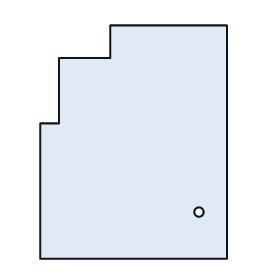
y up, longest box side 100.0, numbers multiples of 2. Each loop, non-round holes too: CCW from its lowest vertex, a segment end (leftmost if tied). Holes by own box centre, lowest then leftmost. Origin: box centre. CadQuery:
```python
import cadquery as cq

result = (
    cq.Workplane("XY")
    .moveTo(-40.0, -50.0)
    .lineTo(40.0, -50.0)
    .lineTo(40.0, 50.0)
    .lineTo(-10.0, 50.0)
    .lineTo(-10.0, 36.0)
    .lineTo(-32.0, 36.0)
    .lineTo(-32.0, 8.0)
    .lineTo(-40.0, 8.0)
    .close()
    .moveTo(28.0, -30.0)
    .circle(2.0)
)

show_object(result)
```